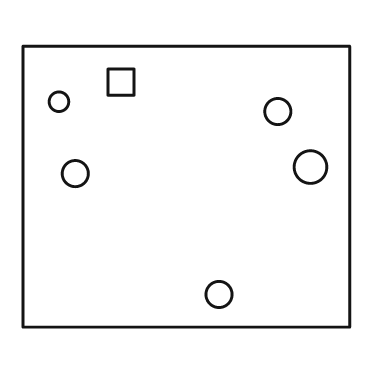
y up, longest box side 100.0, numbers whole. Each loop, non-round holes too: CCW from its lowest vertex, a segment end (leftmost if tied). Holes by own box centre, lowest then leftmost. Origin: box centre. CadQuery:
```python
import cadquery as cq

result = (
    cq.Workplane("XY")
    .moveTo(-50.0, -43.0)
    .lineTo(50.0, -43.0)
    .lineTo(50.0, 43.0)
    .lineTo(-50.0, 43.0)
    .close()
    .moveTo(10.0, -33.0)
    .circle(4.0)
    .moveTo(-34.0, 4.0)
    .circle(4.0)
    .moveTo(38.0, 6.0)
    .circle(5.0)
    .moveTo(28.0, 23.0)
    .circle(4.0)
    .moveTo(-39.0, 26.0)
    .circle(3.0)
    .moveTo(-24.0, 28.0)
    .lineTo(-16.0, 28.0)
    .lineTo(-16.0, 36.0)
    .lineTo(-24.0, 36.0)
    .close()
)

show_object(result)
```